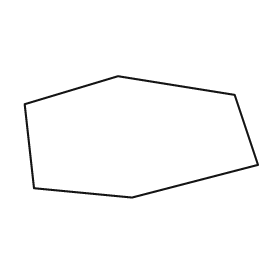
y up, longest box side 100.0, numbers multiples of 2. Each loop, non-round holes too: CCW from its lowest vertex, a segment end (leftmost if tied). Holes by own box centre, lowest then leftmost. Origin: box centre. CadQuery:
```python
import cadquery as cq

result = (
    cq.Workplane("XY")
    .moveTo(-4.0, -26.0)
    .lineTo(50.0, -12.0)
    .lineTo(40.0, 18.0)
    .lineTo(-10.0, 26.0)
    .lineTo(-50.0, 14.0)
    .lineTo(-46.0, -22.0)
    .close()
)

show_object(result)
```